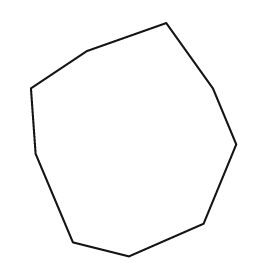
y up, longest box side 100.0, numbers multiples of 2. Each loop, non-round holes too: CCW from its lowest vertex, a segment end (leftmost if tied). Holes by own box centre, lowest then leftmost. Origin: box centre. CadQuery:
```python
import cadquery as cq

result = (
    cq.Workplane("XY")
    .moveTo(-2.0, -50.0)
    .lineTo(30.0, -36.0)
    .lineTo(44.0, -2.0)
    .lineTo(34.0, 22.0)
    .lineTo(14.0, 50.0)
    .lineTo(-20.0, 38.0)
    .lineTo(-44.0, 22.0)
    .lineTo(-42.0, -6.0)
    .lineTo(-26.0, -44.0)
    .close()
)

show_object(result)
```